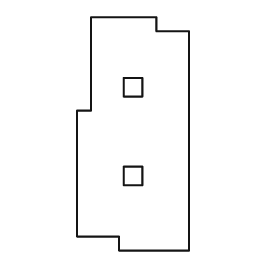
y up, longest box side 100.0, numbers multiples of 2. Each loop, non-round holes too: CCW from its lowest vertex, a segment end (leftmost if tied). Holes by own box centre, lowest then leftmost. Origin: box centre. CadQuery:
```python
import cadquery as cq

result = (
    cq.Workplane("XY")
    .moveTo(-6.0, -50.0)
    .lineTo(24.0, -50.0)
    .lineTo(24.0, 44.0)
    .lineTo(10.0, 44.0)
    .lineTo(10.0, 50.0)
    .lineTo(-18.0, 50.0)
    .lineTo(-18.0, 10.0)
    .lineTo(-24.0, 10.0)
    .lineTo(-24.0, -44.0)
    .lineTo(-6.0, -44.0)
    .close()
    .moveTo(-4.0, -22.0)
    .lineTo(4.0, -22.0)
    .lineTo(4.0, -14.0)
    .lineTo(-4.0, -14.0)
    .close()
    .moveTo(-4.0, 16.0)
    .lineTo(4.0, 16.0)
    .lineTo(4.0, 24.0)
    .lineTo(-4.0, 24.0)
    .close()
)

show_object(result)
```